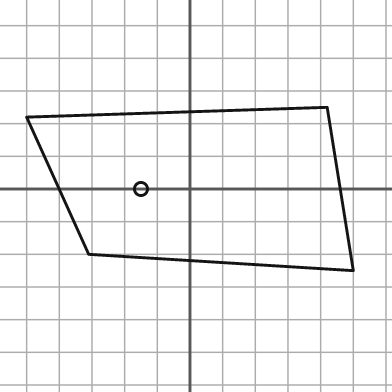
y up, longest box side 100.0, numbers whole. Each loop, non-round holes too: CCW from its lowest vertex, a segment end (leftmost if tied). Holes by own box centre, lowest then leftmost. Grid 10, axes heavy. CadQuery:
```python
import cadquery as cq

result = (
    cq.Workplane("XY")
    .moveTo(50.0, -25.0)
    .lineTo(42.0, 25.0)
    .lineTo(-50.0, 22.0)
    .lineTo(-31.0, -20.0)
    .close()
    .moveTo(-15.0, 0.0)
    .circle(2.0)
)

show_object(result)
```